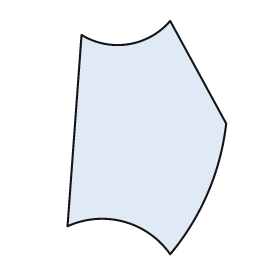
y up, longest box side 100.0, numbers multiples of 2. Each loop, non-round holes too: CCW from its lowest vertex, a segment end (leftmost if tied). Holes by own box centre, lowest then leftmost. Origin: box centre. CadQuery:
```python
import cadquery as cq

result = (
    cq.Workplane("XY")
    .moveTo(10.0, -50.0)
    .threePointArc((26.0, -24.0), (34.0, 6.0))
    .lineTo(10.0, 50.0)
    .threePointArc((-8.0, 40.0), (-28.0, 44.0))
    .lineTo(-34.0, -38.0)
    .threePointArc((-10.0, -36.0), (10.0, -50.0))
    .close()
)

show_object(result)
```